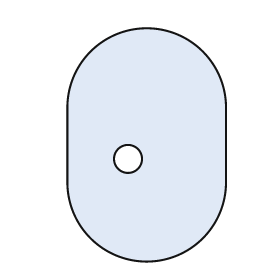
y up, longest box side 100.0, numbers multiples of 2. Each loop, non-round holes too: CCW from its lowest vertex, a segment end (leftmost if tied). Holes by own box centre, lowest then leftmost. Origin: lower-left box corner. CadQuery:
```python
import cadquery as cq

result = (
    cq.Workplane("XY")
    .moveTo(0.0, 34.0)
    .threePointArc((34.0, 0.0), (68.0, 34.0))
    .lineTo(68.0, 66.0)
    .threePointArc((34.0, 100.0), (0.0, 66.0))
    .close()
    .moveTo(26.0, 44.0)
    .circle(6.0)
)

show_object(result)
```